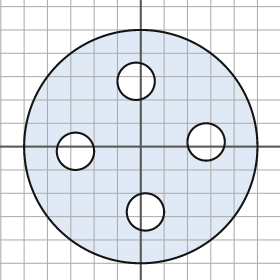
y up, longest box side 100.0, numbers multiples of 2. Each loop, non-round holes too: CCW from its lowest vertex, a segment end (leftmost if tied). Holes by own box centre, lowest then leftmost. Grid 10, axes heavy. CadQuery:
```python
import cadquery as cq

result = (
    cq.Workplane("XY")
    .moveTo(0.0, 0.0)
    .circle(50.0)
    .moveTo(2.0, -28.0)
    .circle(8.0)
    .moveTo(-28.0, -2.0)
    .circle(8.0)
    .moveTo(28.0, 2.0)
    .circle(8.0)
    .moveTo(-2.0, 28.0)
    .circle(8.0)
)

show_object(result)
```